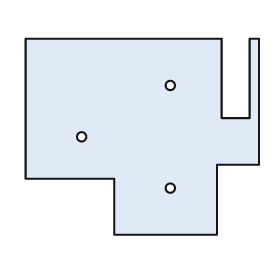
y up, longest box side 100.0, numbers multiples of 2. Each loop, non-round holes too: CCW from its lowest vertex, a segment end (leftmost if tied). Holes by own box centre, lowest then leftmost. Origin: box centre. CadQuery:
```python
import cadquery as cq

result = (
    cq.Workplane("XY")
    .moveTo(-12.0, -42.0)
    .lineTo(32.0, -42.0)
    .lineTo(32.0, -12.0)
    .lineTo(50.0, -12.0)
    .lineTo(50.0, 42.0)
    .lineTo(46.0, 42.0)
    .lineTo(46.0, 8.0)
    .lineTo(34.0, 8.0)
    .lineTo(34.0, 42.0)
    .lineTo(-50.0, 42.0)
    .lineTo(-50.0, -18.0)
    .lineTo(-12.0, -18.0)
    .close()
    .moveTo(12.0, -22.0)
    .circle(2.0)
    .moveTo(-26.0, 0.0)
    .circle(2.0)
    .moveTo(12.0, 22.0)
    .circle(2.0)
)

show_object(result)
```